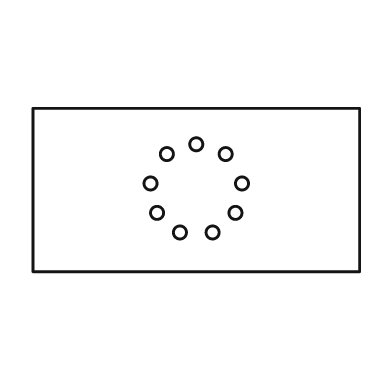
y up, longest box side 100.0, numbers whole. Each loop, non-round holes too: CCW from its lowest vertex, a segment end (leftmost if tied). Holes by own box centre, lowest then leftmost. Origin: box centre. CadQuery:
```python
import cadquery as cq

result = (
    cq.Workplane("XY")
    .moveTo(-50.0, -25.0)
    .lineTo(50.0, -25.0)
    .lineTo(50.0, 25.0)
    .lineTo(-50.0, 25.0)
    .close()
    .moveTo(-5.0, -13.0)
    .circle(2.0)
    .moveTo(5.0, -13.0)
    .circle(2.0)
    .moveTo(-12.0, -7.0)
    .circle(2.0)
    .moveTo(12.0, -7.0)
    .circle(2.0)
    .moveTo(-14.0, 2.0)
    .circle(2.0)
    .moveTo(14.0, 2.0)
    .circle(2.0)
    .moveTo(-9.0, 11.0)
    .circle(2.0)
    .moveTo(9.0, 11.0)
    .circle(2.0)
    .moveTo(0.0, 14.0)
    .circle(2.0)
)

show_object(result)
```